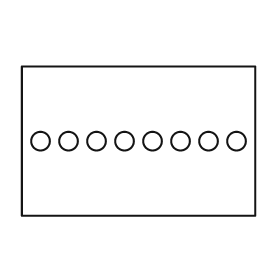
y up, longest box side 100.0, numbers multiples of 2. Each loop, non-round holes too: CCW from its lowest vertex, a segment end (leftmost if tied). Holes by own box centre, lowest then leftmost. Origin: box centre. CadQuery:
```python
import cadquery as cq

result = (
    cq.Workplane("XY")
    .moveTo(-50.0, -32.0)
    .lineTo(50.0, -32.0)
    .lineTo(50.0, 32.0)
    .lineTo(-50.0, 32.0)
    .close()
    .moveTo(-42.0, 0.0)
    .circle(4.0)
    .moveTo(-30.0, 0.0)
    .circle(4.0)
    .moveTo(-18.0, 0.0)
    .circle(4.0)
    .moveTo(-6.0, 0.0)
    .circle(4.0)
    .moveTo(6.0, 0.0)
    .circle(4.0)
    .moveTo(18.0, 0.0)
    .circle(4.0)
    .moveTo(30.0, 0.0)
    .circle(4.0)
    .moveTo(42.0, 0.0)
    .circle(4.0)
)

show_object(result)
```